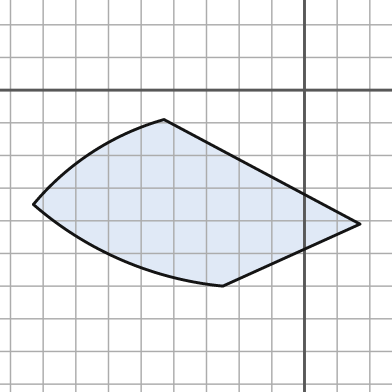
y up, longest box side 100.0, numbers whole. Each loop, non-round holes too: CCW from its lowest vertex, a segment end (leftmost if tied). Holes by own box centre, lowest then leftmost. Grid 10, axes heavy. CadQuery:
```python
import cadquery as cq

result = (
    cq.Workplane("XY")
    .moveTo(-25.0, -60.0)
    .lineTo(17.0, -41.0)
    .lineTo(-43.0, -9.0)
    .threePointArc((-65.0, -19.0), (-83.0, -35.0))
    .threePointArc((-56.0, -52.0), (-25.0, -60.0))
    .close()
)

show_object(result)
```